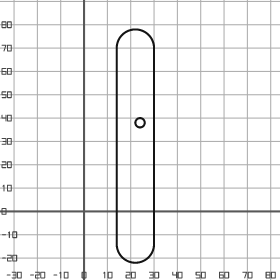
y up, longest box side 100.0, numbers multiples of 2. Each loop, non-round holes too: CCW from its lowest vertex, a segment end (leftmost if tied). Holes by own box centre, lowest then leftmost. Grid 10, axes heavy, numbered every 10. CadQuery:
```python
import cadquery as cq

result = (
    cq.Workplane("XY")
    .moveTo(14.0, -14.0)
    .threePointArc((22.0, -22.0), (30.0, -14.0))
    .lineTo(30.0, 70.0)
    .threePointArc((22.0, 78.0), (14.0, 70.0))
    .close()
    .moveTo(24.0, 38.0)
    .circle(2.0)
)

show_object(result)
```